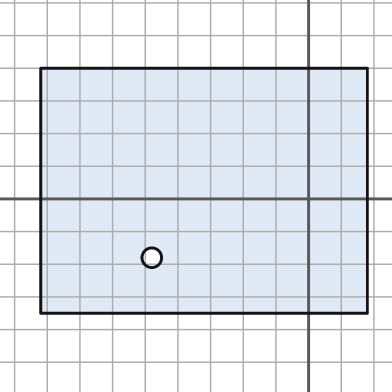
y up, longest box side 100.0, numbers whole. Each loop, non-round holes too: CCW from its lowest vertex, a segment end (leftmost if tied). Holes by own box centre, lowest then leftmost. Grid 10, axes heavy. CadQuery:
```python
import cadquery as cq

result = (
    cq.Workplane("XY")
    .moveTo(-82.0, -35.0)
    .lineTo(18.0, -35.0)
    .lineTo(18.0, 40.0)
    .lineTo(-82.0, 40.0)
    .close()
    .moveTo(-48.0, -18.0)
    .circle(3.0)
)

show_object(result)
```